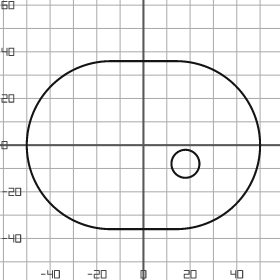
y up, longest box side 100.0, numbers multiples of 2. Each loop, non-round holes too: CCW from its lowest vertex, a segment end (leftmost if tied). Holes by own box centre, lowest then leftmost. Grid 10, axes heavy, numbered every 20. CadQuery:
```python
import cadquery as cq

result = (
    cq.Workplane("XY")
    .moveTo(-14.0, -36.0)
    .lineTo(14.0, -36.0)
    .threePointArc((50.0, 0.0), (14.0, 36.0))
    .lineTo(-14.0, 36.0)
    .threePointArc((-50.0, 0.0), (-14.0, -36.0))
    .close()
    .moveTo(18.0, -8.0)
    .circle(6.0)
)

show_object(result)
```